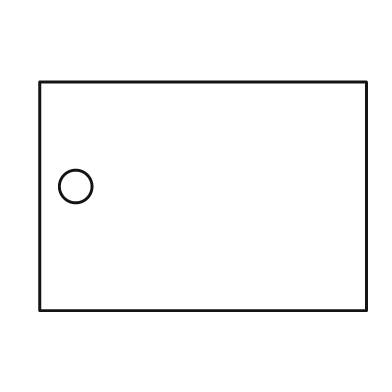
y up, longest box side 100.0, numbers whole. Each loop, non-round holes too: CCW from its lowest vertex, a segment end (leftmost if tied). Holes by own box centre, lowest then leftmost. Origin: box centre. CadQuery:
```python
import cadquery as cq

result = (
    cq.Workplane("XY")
    .moveTo(-50.0, -35.0)
    .lineTo(50.0, -35.0)
    .lineTo(50.0, 35.0)
    .lineTo(-50.0, 35.0)
    .close()
    .moveTo(-39.0, 3.0)
    .circle(5.0)
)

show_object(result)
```